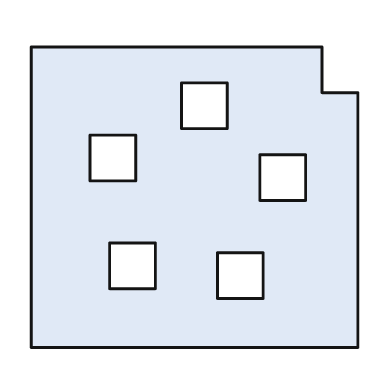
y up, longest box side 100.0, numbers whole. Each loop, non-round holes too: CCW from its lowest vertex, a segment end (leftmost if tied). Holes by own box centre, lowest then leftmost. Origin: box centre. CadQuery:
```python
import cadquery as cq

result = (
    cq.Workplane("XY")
    .moveTo(-50.0, -46.0)
    .lineTo(50.0, -46.0)
    .lineTo(50.0, 32.0)
    .lineTo(39.0, 32.0)
    .lineTo(39.0, 46.0)
    .lineTo(-50.0, 46.0)
    .close()
    .moveTo(7.0, -31.0)
    .lineTo(21.0, -31.0)
    .lineTo(21.0, -17.0)
    .lineTo(7.0, -17.0)
    .close()
    .moveTo(-26.0, -28.0)
    .lineTo(-12.0, -28.0)
    .lineTo(-12.0, -14.0)
    .lineTo(-26.0, -14.0)
    .close()
    .moveTo(20.0, -1.0)
    .lineTo(34.0, -1.0)
    .lineTo(34.0, 13.0)
    .lineTo(20.0, 13.0)
    .close()
    .moveTo(-32.0, 5.0)
    .lineTo(-18.0, 5.0)
    .lineTo(-18.0, 19.0)
    .lineTo(-32.0, 19.0)
    .close()
    .moveTo(-4.0, 21.0)
    .lineTo(10.0, 21.0)
    .lineTo(10.0, 35.0)
    .lineTo(-4.0, 35.0)
    .close()
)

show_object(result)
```